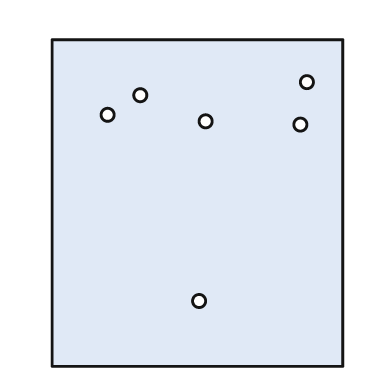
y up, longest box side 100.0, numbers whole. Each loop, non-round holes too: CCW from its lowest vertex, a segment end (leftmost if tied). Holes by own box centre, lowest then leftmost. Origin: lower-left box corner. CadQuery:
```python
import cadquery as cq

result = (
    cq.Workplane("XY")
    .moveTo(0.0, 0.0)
    .lineTo(89.0, 0.0)
    .lineTo(89.0, 100.0)
    .lineTo(0.0, 100.0)
    .close()
    .moveTo(45.0, 20.0)
    .circle(2.0)
    .moveTo(76.0, 74.0)
    .circle(2.0)
    .moveTo(47.0, 75.0)
    .circle(2.0)
    .moveTo(17.0, 77.0)
    .circle(2.0)
    .moveTo(27.0, 83.0)
    .circle(2.0)
    .moveTo(78.0, 87.0)
    .circle(2.0)
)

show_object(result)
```